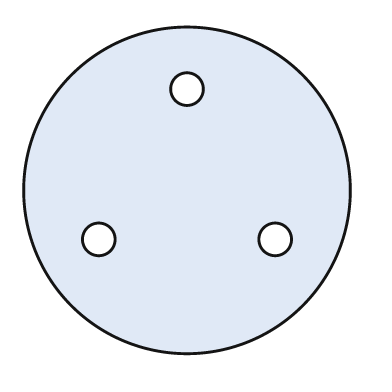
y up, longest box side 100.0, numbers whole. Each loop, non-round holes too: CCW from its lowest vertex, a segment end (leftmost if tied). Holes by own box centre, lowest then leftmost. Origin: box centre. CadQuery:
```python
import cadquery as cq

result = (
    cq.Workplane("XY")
    .moveTo(0.0, 0.0)
    .circle(50.0)
    .moveTo(-27.0, -15.0)
    .circle(5.0)
    .moveTo(27.0, -15.0)
    .circle(5.0)
    .moveTo(0.0, 31.0)
    .circle(5.0)
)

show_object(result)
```